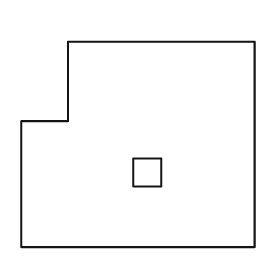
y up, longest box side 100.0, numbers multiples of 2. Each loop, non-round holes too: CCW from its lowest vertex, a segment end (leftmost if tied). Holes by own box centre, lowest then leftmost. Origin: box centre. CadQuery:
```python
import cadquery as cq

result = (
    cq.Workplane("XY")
    .moveTo(-50.0, -44.0)
    .lineTo(50.0, -44.0)
    .lineTo(50.0, 44.0)
    .lineTo(-30.0, 44.0)
    .lineTo(-30.0, 10.0)
    .lineTo(-50.0, 10.0)
    .close()
    .moveTo(-2.0, -18.0)
    .lineTo(10.0, -18.0)
    .lineTo(10.0, -6.0)
    .lineTo(-2.0, -6.0)
    .close()
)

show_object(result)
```